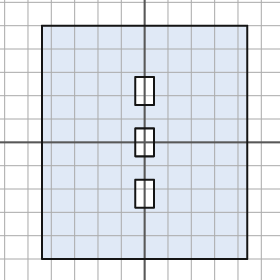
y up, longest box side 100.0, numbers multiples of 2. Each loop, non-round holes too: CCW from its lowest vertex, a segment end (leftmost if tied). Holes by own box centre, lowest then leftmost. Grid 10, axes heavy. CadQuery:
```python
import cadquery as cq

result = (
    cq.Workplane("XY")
    .moveTo(-44.0, -50.0)
    .lineTo(44.0, -50.0)
    .lineTo(44.0, 50.0)
    .lineTo(-44.0, 50.0)
    .close()
    .moveTo(-4.0, -28.0)
    .lineTo(4.0, -28.0)
    .lineTo(4.0, -16.0)
    .lineTo(-4.0, -16.0)
    .close()
    .moveTo(-4.0, -6.0)
    .lineTo(4.0, -6.0)
    .lineTo(4.0, 6.0)
    .lineTo(-4.0, 6.0)
    .close()
    .moveTo(-4.0, 16.0)
    .lineTo(4.0, 16.0)
    .lineTo(4.0, 28.0)
    .lineTo(-4.0, 28.0)
    .close()
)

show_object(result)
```